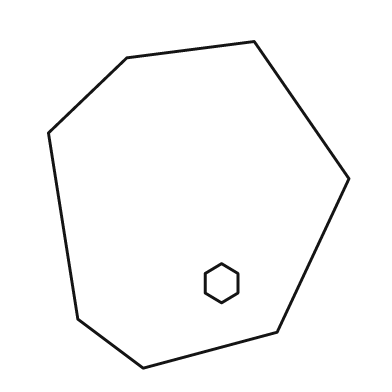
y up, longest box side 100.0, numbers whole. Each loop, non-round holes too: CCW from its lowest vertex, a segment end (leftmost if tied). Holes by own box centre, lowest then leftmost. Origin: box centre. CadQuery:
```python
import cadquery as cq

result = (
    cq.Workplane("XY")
    .moveTo(-17.0, -50.0)
    .lineTo(24.0, -39.0)
    .lineTo(46.0, 8.0)
    .lineTo(17.0, 50.0)
    .lineTo(-22.0, 45.0)
    .lineTo(-46.0, 22.0)
    .lineTo(-37.0, -35.0)
    .close()
    .moveTo(7.0, -30.0)
    .lineTo(12.0, -27.0)
    .lineTo(12.0, -21.0)
    .lineTo(7.0, -18.0)
    .lineTo(2.0, -21.0)
    .lineTo(2.0, -27.0)
    .close()
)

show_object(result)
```